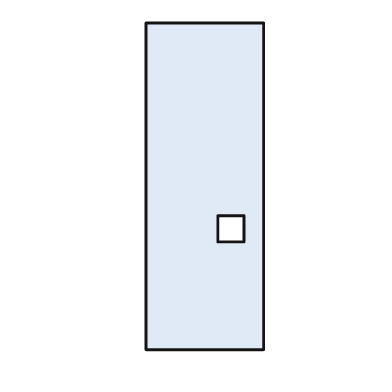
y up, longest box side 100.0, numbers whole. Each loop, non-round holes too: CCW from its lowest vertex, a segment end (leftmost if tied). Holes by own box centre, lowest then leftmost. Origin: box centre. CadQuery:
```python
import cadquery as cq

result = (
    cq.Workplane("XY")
    .moveTo(-18.0, -50.0)
    .lineTo(18.0, -50.0)
    .lineTo(18.0, 50.0)
    .lineTo(-18.0, 50.0)
    .close()
    .moveTo(4.0, -17.0)
    .lineTo(12.0, -17.0)
    .lineTo(12.0, -9.0)
    .lineTo(4.0, -9.0)
    .close()
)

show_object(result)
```